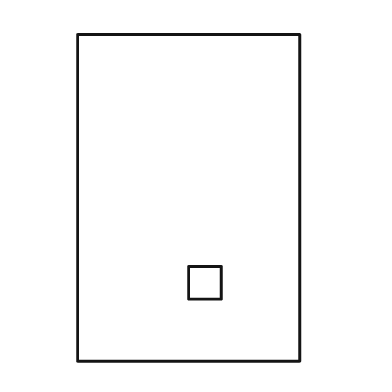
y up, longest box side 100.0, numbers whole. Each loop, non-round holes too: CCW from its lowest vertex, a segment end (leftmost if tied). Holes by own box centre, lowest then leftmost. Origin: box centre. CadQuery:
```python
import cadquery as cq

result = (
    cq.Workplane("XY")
    .moveTo(-34.0, -50.0)
    .lineTo(34.0, -50.0)
    .lineTo(34.0, 50.0)
    .lineTo(-34.0, 50.0)
    .close()
    .moveTo(0.0, -31.0)
    .lineTo(10.0, -31.0)
    .lineTo(10.0, -21.0)
    .lineTo(0.0, -21.0)
    .close()
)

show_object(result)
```